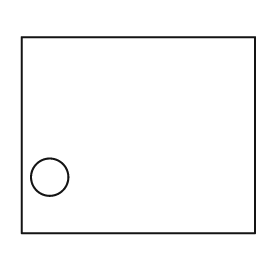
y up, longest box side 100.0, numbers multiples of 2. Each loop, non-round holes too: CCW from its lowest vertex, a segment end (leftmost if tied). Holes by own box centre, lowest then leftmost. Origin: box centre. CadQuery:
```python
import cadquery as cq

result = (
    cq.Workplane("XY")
    .moveTo(-50.0, -42.0)
    .lineTo(50.0, -42.0)
    .lineTo(50.0, 42.0)
    .lineTo(-50.0, 42.0)
    .close()
    .moveTo(-38.0, -18.0)
    .circle(8.0)
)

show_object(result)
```